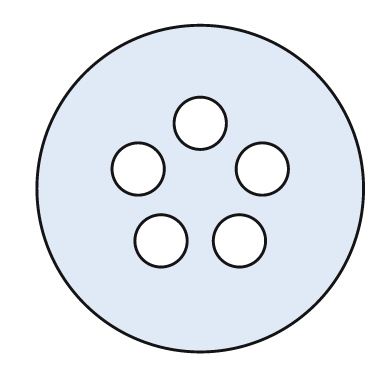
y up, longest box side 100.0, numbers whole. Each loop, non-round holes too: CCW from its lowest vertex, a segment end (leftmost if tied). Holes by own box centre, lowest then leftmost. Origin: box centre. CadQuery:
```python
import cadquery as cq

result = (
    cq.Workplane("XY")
    .moveTo(0.0, 0.0)
    .circle(50.0)
    .moveTo(-12.0, -16.0)
    .circle(8.0)
    .moveTo(12.0, -16.0)
    .circle(8.0)
    .moveTo(-19.0, 6.0)
    .circle(8.0)
    .moveTo(19.0, 6.0)
    .circle(8.0)
    .moveTo(0.0, 20.0)
    .circle(8.0)
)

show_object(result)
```